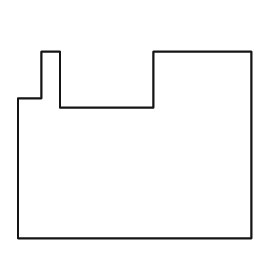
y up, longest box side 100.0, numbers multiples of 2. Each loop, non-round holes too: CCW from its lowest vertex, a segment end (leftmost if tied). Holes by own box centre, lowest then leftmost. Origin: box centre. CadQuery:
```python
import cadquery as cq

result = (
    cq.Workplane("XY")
    .moveTo(-50.0, -40.0)
    .lineTo(50.0, -40.0)
    .lineTo(50.0, 40.0)
    .lineTo(8.0, 40.0)
    .lineTo(8.0, 16.0)
    .lineTo(-32.0, 16.0)
    .lineTo(-32.0, 40.0)
    .lineTo(-40.0, 40.0)
    .lineTo(-40.0, 20.0)
    .lineTo(-50.0, 20.0)
    .close()
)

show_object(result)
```